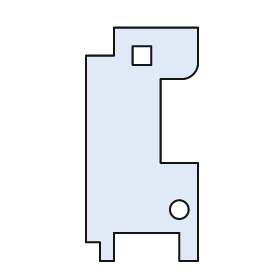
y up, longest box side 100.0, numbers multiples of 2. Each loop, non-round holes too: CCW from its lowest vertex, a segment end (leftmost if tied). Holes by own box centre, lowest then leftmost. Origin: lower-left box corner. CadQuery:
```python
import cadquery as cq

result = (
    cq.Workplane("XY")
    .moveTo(6.0, 0.0)
    .lineTo(12.0, 0.0)
    .lineTo(12.0, 12.0)
    .lineTo(40.0, 12.0)
    .lineTo(40.0, 0.0)
    .lineTo(48.0, 0.0)
    .lineTo(48.0, 42.0)
    .lineTo(32.0, 42.0)
    .lineTo(32.0, 78.0)
    .lineTo(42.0, 78.0)
    .threePointArc((46.0, 80.0), (48.0, 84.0))
    .lineTo(48.0, 100.0)
    .lineTo(12.0, 100.0)
    .lineTo(12.0, 88.0)
    .lineTo(0.0, 88.0)
    .lineTo(0.0, 8.0)
    .lineTo(6.0, 8.0)
    .close()
    .moveTo(40.0, 22.0)
    .circle(4.0)
    .moveTo(20.0, 84.0)
    .lineTo(28.0, 84.0)
    .lineTo(28.0, 92.0)
    .lineTo(20.0, 92.0)
    .close()
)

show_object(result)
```